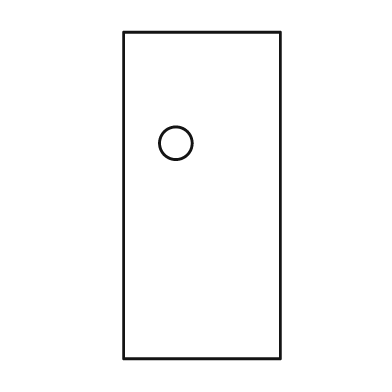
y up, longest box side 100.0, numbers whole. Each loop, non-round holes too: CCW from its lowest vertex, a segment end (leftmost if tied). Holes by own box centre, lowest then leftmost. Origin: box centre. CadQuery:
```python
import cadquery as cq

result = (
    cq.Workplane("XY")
    .moveTo(-24.0, -50.0)
    .lineTo(24.0, -50.0)
    .lineTo(24.0, 50.0)
    .lineTo(-24.0, 50.0)
    .close()
    .moveTo(-8.0, 16.0)
    .circle(5.0)
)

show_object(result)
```